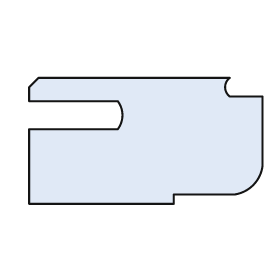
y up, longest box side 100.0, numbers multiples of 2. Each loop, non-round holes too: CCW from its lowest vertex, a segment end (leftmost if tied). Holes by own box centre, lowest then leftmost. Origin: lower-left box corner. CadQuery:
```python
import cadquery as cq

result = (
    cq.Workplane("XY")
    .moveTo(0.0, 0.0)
    .lineTo(62.0, 0.0)
    .lineTo(62.0, 4.0)
    .lineTo(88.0, 4.0)
    .threePointArc((96.0, 8.0), (100.0, 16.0))
    .lineTo(100.0, 46.0)
    .lineTo(86.0, 46.0)
    .threePointArc((84.0, 50.0), (86.0, 54.0))
    .lineTo(4.0, 54.0)
    .lineTo(0.0, 50.0)
    .lineTo(0.0, 44.0)
    .lineTo(38.0, 44.0)
    .threePointArc((40.0, 38.0), (38.0, 32.0))
    .lineTo(0.0, 32.0)
    .close()
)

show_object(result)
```